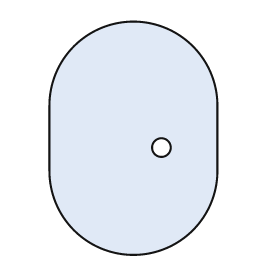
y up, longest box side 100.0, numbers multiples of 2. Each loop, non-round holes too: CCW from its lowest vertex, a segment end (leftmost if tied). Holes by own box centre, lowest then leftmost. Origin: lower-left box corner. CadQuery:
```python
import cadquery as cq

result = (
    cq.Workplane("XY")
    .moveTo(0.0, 36.0)
    .threePointArc((36.0, 0.0), (72.0, 36.0))
    .lineTo(72.0, 64.0)
    .threePointArc((36.0, 100.0), (0.0, 64.0))
    .close()
    .moveTo(48.0, 46.0)
    .circle(4.0)
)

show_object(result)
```